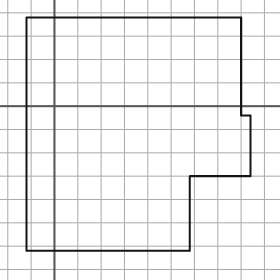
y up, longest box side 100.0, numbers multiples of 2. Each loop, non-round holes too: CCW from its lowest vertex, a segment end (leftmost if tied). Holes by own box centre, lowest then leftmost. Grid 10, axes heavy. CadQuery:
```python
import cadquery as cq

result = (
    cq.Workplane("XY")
    .moveTo(-12.0, -62.0)
    .lineTo(58.0, -62.0)
    .lineTo(58.0, -30.0)
    .lineTo(84.0, -30.0)
    .lineTo(84.0, -4.0)
    .lineTo(80.0, -4.0)
    .lineTo(80.0, 38.0)
    .lineTo(-12.0, 38.0)
    .close()
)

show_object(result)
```